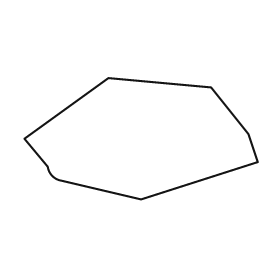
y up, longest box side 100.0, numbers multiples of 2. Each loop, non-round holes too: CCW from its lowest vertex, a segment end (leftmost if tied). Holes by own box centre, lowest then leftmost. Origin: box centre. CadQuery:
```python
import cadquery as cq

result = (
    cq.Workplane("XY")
    .moveTo(0.0, -26.0)
    .lineTo(50.0, -10.0)
    .lineTo(46.0, 2.0)
    .lineTo(30.0, 22.0)
    .lineTo(-14.0, 26.0)
    .lineTo(-50.0, 0.0)
    .lineTo(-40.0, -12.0)
    .threePointArc((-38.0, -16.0), (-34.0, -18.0))
    .close()
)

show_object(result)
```